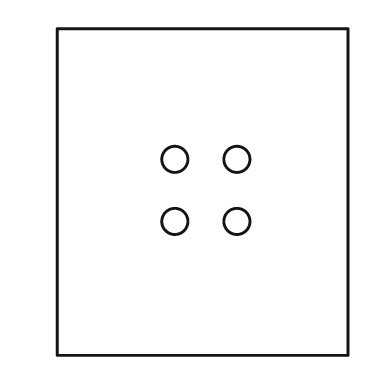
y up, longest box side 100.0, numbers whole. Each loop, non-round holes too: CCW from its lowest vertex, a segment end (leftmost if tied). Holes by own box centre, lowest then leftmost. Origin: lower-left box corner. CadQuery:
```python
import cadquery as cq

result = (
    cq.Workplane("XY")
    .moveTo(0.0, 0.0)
    .lineTo(89.0, 0.0)
    .lineTo(89.0, 100.0)
    .lineTo(0.0, 100.0)
    .close()
    .moveTo(36.0, 41.0)
    .circle(4.0)
    .moveTo(55.0, 41.0)
    .circle(4.0)
    .moveTo(36.0, 60.0)
    .circle(4.0)
    .moveTo(55.0, 60.0)
    .circle(4.0)
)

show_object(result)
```